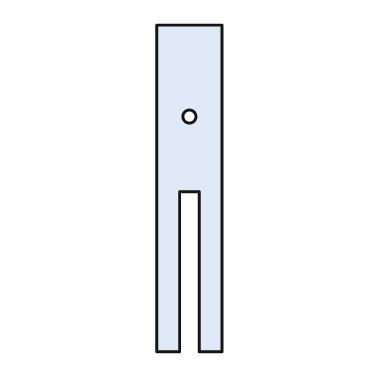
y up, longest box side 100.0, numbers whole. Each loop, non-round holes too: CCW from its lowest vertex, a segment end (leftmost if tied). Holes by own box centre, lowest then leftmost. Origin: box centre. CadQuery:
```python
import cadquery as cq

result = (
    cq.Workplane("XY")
    .moveTo(-10.0, -50.0)
    .lineTo(-3.0, -50.0)
    .lineTo(-3.0, -1.0)
    .lineTo(3.0, -1.0)
    .lineTo(3.0, -50.0)
    .lineTo(10.0, -50.0)
    .lineTo(10.0, 50.0)
    .lineTo(-10.0, 50.0)
    .close()
    .moveTo(0.0, 22.0)
    .circle(2.0)
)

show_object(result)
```